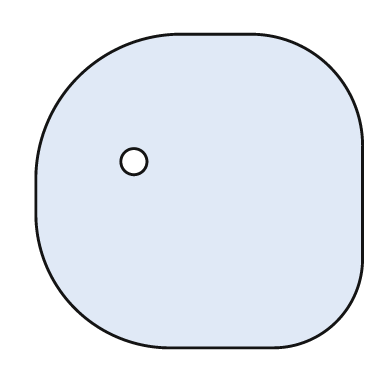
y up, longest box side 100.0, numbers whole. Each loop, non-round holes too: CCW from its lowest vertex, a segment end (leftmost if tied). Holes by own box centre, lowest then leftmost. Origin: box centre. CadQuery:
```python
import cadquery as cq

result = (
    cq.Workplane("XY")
    .moveTo(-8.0, -48.0)
    .lineTo(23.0, -48.0)
    .threePointArc((42.0, -40.0), (50.0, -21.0))
    .lineTo(50.0, 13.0)
    .threePointArc((40.0, 38.0), (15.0, 48.0))
    .lineTo(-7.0, 48.0)
    .threePointArc((-37.0, 35.0), (-50.0, 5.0))
    .lineTo(-50.0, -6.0)
    .threePointArc((-38.0, -36.0), (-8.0, -48.0))
    .close()
    .moveTo(-20.0, 9.0)
    .circle(4.0)
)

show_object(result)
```